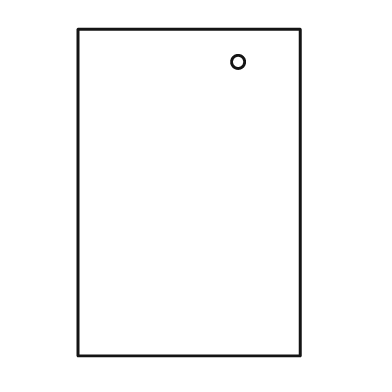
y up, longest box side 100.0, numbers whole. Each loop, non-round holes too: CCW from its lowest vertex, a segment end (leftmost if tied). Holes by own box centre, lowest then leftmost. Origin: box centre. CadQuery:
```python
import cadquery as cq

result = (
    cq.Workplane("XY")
    .moveTo(-34.0, -50.0)
    .lineTo(34.0, -50.0)
    .lineTo(34.0, 50.0)
    .lineTo(-34.0, 50.0)
    .close()
    .moveTo(15.0, 40.0)
    .circle(2.0)
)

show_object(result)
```